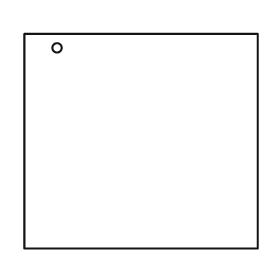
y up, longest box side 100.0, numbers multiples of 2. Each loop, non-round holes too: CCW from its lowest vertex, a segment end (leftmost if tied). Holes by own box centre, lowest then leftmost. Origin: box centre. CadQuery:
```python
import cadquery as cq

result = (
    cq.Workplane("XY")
    .moveTo(-50.0, -46.0)
    .lineTo(50.0, -46.0)
    .lineTo(50.0, 46.0)
    .lineTo(-50.0, 46.0)
    .close()
    .moveTo(-36.0, 40.0)
    .circle(2.0)
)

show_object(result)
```